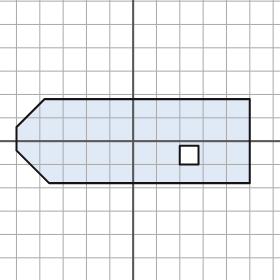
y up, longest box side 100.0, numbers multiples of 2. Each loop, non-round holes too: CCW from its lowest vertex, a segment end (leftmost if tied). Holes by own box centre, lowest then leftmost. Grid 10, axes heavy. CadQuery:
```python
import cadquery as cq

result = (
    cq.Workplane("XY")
    .moveTo(-36.0, -18.0)
    .lineTo(50.0, -18.0)
    .lineTo(50.0, 18.0)
    .lineTo(-38.0, 18.0)
    .lineTo(-50.0, 6.0)
    .lineTo(-50.0, -4.0)
    .close()
    .moveTo(20.0, -10.0)
    .lineTo(28.0, -10.0)
    .lineTo(28.0, -2.0)
    .lineTo(20.0, -2.0)
    .close()
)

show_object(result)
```